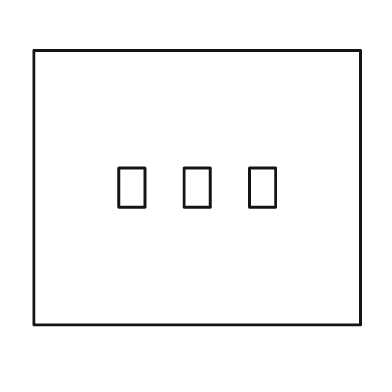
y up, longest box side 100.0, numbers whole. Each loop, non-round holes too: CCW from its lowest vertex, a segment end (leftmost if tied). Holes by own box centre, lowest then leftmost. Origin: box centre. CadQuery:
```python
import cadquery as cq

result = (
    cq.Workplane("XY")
    .moveTo(-50.0, -42.0)
    .lineTo(50.0, -42.0)
    .lineTo(50.0, 42.0)
    .lineTo(-50.0, 42.0)
    .close()
    .moveTo(-24.0, -6.0)
    .lineTo(-16.0, -6.0)
    .lineTo(-16.0, 6.0)
    .lineTo(-24.0, 6.0)
    .close()
    .moveTo(-4.0, -6.0)
    .lineTo(4.0, -6.0)
    .lineTo(4.0, 6.0)
    .lineTo(-4.0, 6.0)
    .close()
    .moveTo(16.0, -6.0)
    .lineTo(24.0, -6.0)
    .lineTo(24.0, 6.0)
    .lineTo(16.0, 6.0)
    .close()
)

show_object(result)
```